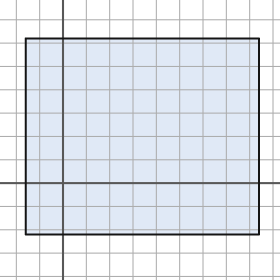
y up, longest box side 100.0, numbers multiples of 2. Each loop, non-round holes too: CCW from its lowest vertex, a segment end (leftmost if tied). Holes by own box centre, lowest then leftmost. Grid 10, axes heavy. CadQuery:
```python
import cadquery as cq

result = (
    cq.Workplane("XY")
    .moveTo(-16.0, -22.0)
    .lineTo(84.0, -22.0)
    .lineTo(84.0, 62.0)
    .lineTo(-16.0, 62.0)
    .close()
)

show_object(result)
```